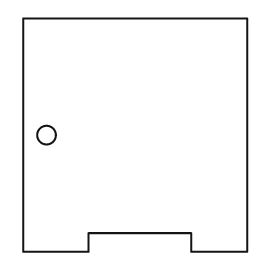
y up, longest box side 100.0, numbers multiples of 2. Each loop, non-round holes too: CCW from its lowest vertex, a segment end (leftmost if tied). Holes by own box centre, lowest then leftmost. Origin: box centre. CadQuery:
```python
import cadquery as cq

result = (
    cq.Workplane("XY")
    .moveTo(-48.0, -50.0)
    .lineTo(-20.0, -50.0)
    .lineTo(-20.0, -42.0)
    .lineTo(24.0, -42.0)
    .lineTo(24.0, -50.0)
    .lineTo(48.0, -50.0)
    .lineTo(48.0, 50.0)
    .lineTo(-48.0, 50.0)
    .close()
    .moveTo(-38.0, 0.0)
    .circle(4.0)
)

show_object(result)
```